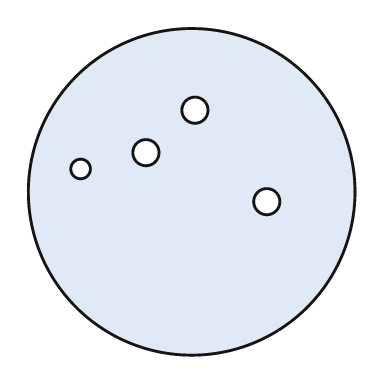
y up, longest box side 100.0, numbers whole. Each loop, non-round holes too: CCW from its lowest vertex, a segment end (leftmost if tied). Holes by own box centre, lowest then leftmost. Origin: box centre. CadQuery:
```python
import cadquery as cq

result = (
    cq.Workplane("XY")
    .moveTo(0.0, 0.0)
    .circle(50.0)
    .moveTo(23.0, -3.0)
    .circle(4.0)
    .moveTo(-34.0, 7.0)
    .circle(3.0)
    .moveTo(-14.0, 12.0)
    .circle(4.0)
    .moveTo(1.0, 25.0)
    .circle(4.0)
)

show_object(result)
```